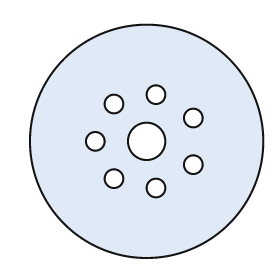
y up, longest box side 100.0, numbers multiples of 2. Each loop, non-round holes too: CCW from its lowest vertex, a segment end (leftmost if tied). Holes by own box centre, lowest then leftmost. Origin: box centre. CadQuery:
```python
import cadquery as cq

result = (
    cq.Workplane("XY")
    .moveTo(0.0, 0.0)
    .circle(50.0)
    .moveTo(4.0, -20.0)
    .circle(4.0)
    .moveTo(-14.0, -16.0)
    .circle(4.0)
    .moveTo(20.0, -10.0)
    .circle(4.0)
    .moveTo(-22.0, 0.0)
    .circle(4.0)
    .moveTo(0.0, 0.0)
    .circle(8.0)
    .moveTo(20.0, 10.0)
    .circle(4.0)
    .moveTo(-14.0, 16.0)
    .circle(4.0)
    .moveTo(4.0, 20.0)
    .circle(4.0)
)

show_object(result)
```